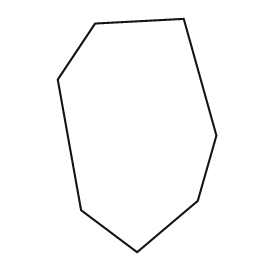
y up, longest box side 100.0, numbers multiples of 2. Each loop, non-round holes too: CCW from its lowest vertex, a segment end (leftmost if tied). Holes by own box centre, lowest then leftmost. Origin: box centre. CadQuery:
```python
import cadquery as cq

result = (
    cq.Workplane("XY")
    .moveTo(0.0, -50.0)
    .lineTo(26.0, -28.0)
    .lineTo(34.0, 0.0)
    .lineTo(20.0, 50.0)
    .lineTo(-18.0, 48.0)
    .lineTo(-34.0, 24.0)
    .lineTo(-24.0, -32.0)
    .close()
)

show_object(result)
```